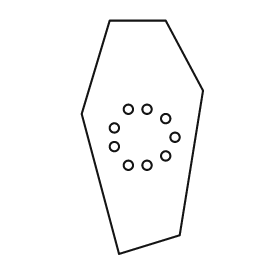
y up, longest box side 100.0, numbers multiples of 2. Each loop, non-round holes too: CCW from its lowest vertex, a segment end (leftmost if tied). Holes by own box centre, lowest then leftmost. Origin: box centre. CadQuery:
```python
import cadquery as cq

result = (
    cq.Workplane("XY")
    .moveTo(-10.0, -50.0)
    .lineTo(16.0, -42.0)
    .lineTo(26.0, 20.0)
    .lineTo(10.0, 50.0)
    .lineTo(-14.0, 50.0)
    .lineTo(-26.0, 10.0)
    .close()
    .moveTo(-6.0, -12.0)
    .circle(2.0)
    .moveTo(2.0, -12.0)
    .circle(2.0)
    .moveTo(10.0, -8.0)
    .circle(2.0)
    .moveTo(-12.0, -4.0)
    .circle(2.0)
    .moveTo(14.0, 0.0)
    .circle(2.0)
    .moveTo(-12.0, 4.0)
    .circle(2.0)
    .moveTo(10.0, 8.0)
    .circle(2.0)
    .moveTo(-6.0, 12.0)
    .circle(2.0)
    .moveTo(2.0, 12.0)
    .circle(2.0)
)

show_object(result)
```